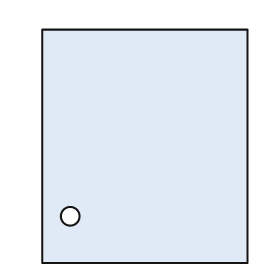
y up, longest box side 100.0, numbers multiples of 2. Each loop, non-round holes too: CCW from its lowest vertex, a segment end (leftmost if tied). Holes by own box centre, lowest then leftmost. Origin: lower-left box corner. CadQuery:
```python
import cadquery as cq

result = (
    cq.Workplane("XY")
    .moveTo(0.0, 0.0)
    .lineTo(88.0, 0.0)
    .lineTo(88.0, 100.0)
    .lineTo(0.0, 100.0)
    .close()
    .moveTo(12.0, 20.0)
    .circle(4.0)
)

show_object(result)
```